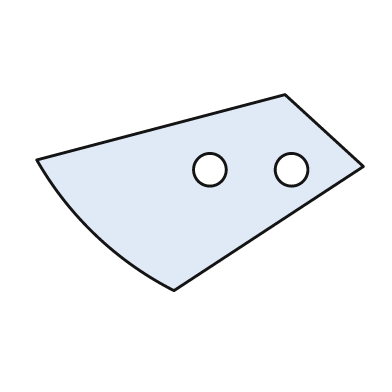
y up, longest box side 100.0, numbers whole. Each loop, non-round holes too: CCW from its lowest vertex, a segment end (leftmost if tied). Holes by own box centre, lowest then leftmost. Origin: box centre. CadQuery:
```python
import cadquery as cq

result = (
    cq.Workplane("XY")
    .moveTo(-8.0, -30.0)
    .lineTo(50.0, 8.0)
    .lineTo(26.0, 30.0)
    .lineTo(-50.0, 10.0)
    .threePointArc((-32.0, -13.0), (-8.0, -30.0))
    .close()
    .moveTo(3.0, 7.0)
    .circle(5.0)
    .moveTo(28.0, 7.0)
    .circle(5.0)
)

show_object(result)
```